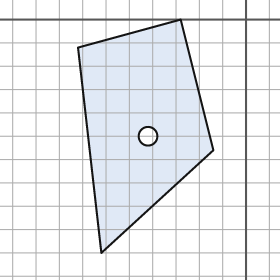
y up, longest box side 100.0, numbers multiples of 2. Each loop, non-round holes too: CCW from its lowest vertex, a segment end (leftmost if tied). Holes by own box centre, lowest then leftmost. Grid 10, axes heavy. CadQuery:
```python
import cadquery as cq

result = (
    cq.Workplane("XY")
    .moveTo(-62.0, -100.0)
    .lineTo(-14.0, -56.0)
    .lineTo(-28.0, 0.0)
    .lineTo(-72.0, -12.0)
    .close()
    .moveTo(-42.0, -50.0)
    .circle(4.0)
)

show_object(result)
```